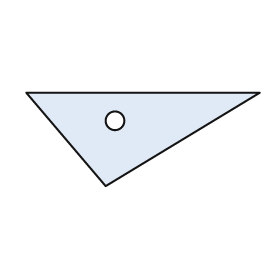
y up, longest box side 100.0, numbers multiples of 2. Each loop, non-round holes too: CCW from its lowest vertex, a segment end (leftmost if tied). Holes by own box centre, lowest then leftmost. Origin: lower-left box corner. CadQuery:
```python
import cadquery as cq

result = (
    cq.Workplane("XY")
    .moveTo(34.0, 0.0)
    .lineTo(100.0, 40.0)
    .lineTo(0.0, 40.0)
    .close()
    .moveTo(38.0, 28.0)
    .circle(4.0)
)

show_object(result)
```